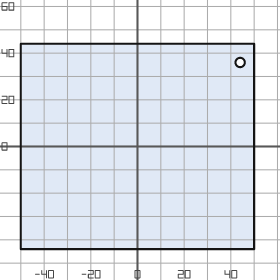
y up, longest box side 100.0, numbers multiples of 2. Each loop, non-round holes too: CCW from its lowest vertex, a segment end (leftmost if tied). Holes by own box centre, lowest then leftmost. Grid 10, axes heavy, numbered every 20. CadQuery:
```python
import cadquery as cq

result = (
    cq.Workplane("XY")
    .moveTo(-50.0, -44.0)
    .lineTo(50.0, -44.0)
    .lineTo(50.0, 44.0)
    .lineTo(-50.0, 44.0)
    .close()
    .moveTo(44.0, 36.0)
    .circle(2.0)
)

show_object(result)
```